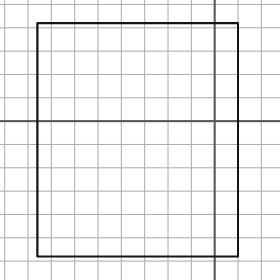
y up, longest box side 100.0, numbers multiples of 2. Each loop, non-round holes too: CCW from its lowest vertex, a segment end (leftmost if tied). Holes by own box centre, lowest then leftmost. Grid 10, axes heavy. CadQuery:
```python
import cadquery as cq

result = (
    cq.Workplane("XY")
    .moveTo(-76.0, -58.0)
    .lineTo(10.0, -58.0)
    .lineTo(10.0, 42.0)
    .lineTo(-76.0, 42.0)
    .close()
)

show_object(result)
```